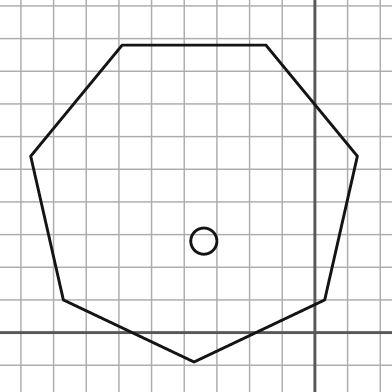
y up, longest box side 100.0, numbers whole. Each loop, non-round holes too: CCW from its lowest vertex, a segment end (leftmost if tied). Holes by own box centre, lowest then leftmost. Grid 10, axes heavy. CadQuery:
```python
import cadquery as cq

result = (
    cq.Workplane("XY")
    .moveTo(-37.0, -9.0)
    .lineTo(3.0, 10.0)
    .lineTo(13.0, 54.0)
    .lineTo(-15.0, 88.0)
    .lineTo(-59.0, 88.0)
    .lineTo(-87.0, 54.0)
    .lineTo(-77.0, 10.0)
    .close()
    .moveTo(-34.0, 28.0)
    .circle(4.0)
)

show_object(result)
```